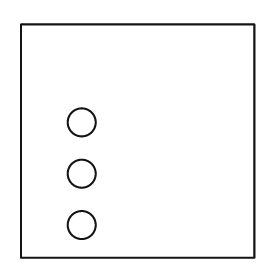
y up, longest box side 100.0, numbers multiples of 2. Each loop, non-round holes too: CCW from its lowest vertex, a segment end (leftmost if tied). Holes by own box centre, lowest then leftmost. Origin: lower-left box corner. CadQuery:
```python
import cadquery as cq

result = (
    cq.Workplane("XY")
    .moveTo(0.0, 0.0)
    .lineTo(100.0, 0.0)
    .lineTo(100.0, 100.0)
    .lineTo(0.0, 100.0)
    .close()
    .moveTo(26.0, 14.0)
    .circle(6.0)
    .moveTo(26.0, 36.0)
    .circle(6.0)
    .moveTo(26.0, 58.0)
    .circle(6.0)
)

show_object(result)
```